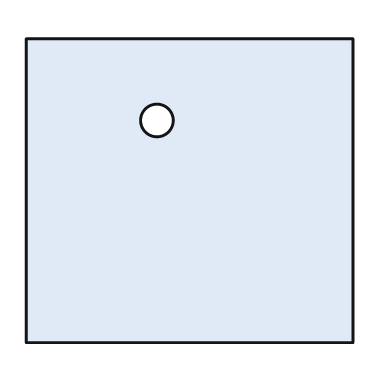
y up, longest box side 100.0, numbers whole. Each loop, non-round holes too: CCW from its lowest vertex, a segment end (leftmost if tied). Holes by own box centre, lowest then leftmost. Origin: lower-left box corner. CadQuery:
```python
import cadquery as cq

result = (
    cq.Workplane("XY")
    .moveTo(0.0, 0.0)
    .lineTo(100.0, 0.0)
    .lineTo(100.0, 93.0)
    .lineTo(0.0, 93.0)
    .close()
    .moveTo(40.0, 68.0)
    .circle(5.0)
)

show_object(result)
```